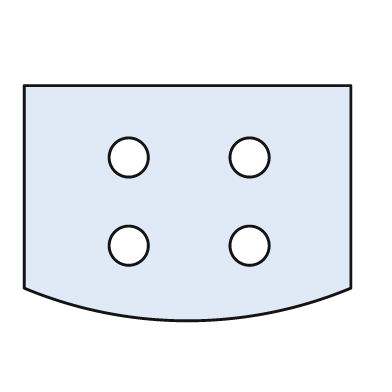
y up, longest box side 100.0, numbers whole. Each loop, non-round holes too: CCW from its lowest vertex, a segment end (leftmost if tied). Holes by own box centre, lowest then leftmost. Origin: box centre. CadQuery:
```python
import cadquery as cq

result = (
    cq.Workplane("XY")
    .moveTo(-50.0, -26.0)
    .threePointArc((0.0, -36.0), (50.0, -26.0))
    .lineTo(50.0, 36.0)
    .lineTo(-50.0, 36.0)
    .close()
    .moveTo(-18.0, -13.0)
    .circle(6.0)
    .moveTo(19.0, -13.0)
    .circle(6.0)
    .moveTo(-18.0, 14.0)
    .circle(6.0)
    .moveTo(19.0, 14.0)
    .circle(6.0)
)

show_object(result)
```